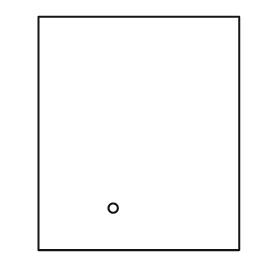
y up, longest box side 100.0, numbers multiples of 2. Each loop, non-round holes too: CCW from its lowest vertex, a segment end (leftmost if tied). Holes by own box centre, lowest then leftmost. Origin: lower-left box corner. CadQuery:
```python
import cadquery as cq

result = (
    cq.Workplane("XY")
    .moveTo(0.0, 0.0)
    .lineTo(86.0, 0.0)
    .lineTo(86.0, 100.0)
    .lineTo(0.0, 100.0)
    .close()
    .moveTo(32.0, 18.0)
    .circle(2.0)
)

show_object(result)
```